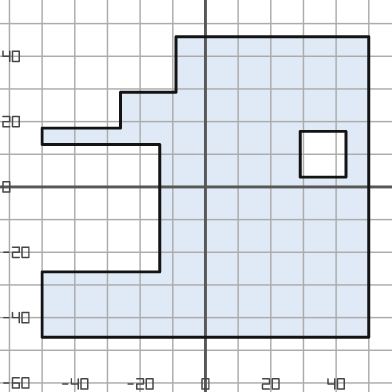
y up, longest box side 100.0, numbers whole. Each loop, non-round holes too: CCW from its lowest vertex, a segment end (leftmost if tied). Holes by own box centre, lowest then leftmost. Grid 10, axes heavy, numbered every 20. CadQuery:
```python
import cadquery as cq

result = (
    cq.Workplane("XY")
    .moveTo(-50.0, -46.0)
    .lineTo(50.0, -46.0)
    .lineTo(50.0, 46.0)
    .lineTo(-9.0, 46.0)
    .lineTo(-9.0, 29.0)
    .lineTo(-26.0, 29.0)
    .lineTo(-26.0, 18.0)
    .lineTo(-50.0, 18.0)
    .lineTo(-50.0, 13.0)
    .lineTo(-14.0, 13.0)
    .lineTo(-14.0, -26.0)
    .lineTo(-50.0, -26.0)
    .close()
    .moveTo(29.0, 3.0)
    .lineTo(43.0, 3.0)
    .lineTo(43.0, 17.0)
    .lineTo(29.0, 17.0)
    .close()
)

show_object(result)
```